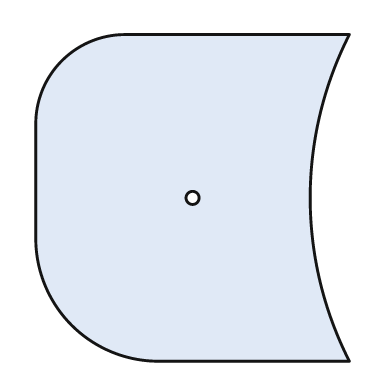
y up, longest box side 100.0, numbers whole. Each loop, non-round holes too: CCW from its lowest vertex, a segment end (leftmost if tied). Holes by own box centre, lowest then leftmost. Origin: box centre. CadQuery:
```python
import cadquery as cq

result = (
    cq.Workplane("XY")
    .moveTo(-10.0, -50.0)
    .lineTo(48.0, -50.0)
    .threePointArc((36.0, 0.0), (48.0, 50.0))
    .lineTo(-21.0, 50.0)
    .threePointArc((-40.0, 42.0), (-48.0, 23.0))
    .lineTo(-48.0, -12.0)
    .threePointArc((-37.0, -39.0), (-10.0, -50.0))
    .close()
    .moveTo(0.0, 0.0)
    .circle(2.0)
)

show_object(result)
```